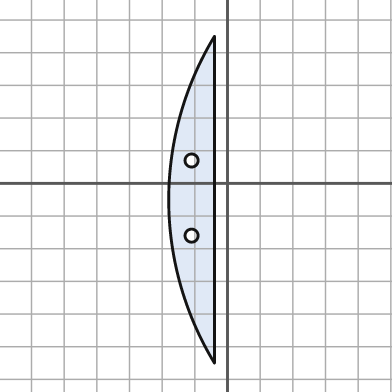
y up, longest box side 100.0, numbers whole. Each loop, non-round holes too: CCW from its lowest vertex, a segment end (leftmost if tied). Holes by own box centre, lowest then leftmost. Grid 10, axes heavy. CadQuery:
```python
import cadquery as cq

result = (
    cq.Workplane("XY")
    .moveTo(-4.0, -55.0)
    .lineTo(-4.0, 45.0)
    .threePointArc((-18.0, -5.0), (-4.0, -55.0))
    .close()
    .moveTo(-11.0, -16.0)
    .circle(2.0)
    .moveTo(-11.0, 7.0)
    .circle(2.0)
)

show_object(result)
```